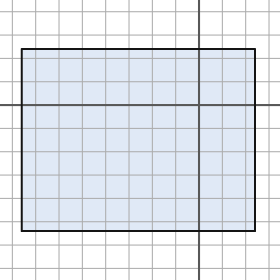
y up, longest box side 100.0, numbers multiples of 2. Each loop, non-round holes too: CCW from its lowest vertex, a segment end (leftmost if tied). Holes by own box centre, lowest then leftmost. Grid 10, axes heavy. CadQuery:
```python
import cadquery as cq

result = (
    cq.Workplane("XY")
    .moveTo(-76.0, -54.0)
    .lineTo(24.0, -54.0)
    .lineTo(24.0, 24.0)
    .lineTo(-76.0, 24.0)
    .close()
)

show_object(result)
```